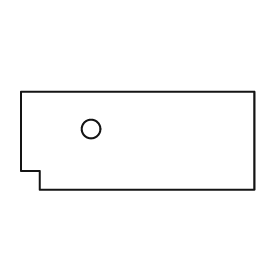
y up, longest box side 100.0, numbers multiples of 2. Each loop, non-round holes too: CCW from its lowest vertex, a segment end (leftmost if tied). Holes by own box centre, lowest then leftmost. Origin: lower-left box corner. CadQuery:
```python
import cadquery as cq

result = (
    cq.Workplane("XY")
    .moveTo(8.0, 0.0)
    .lineTo(100.0, 0.0)
    .lineTo(100.0, 42.0)
    .lineTo(0.0, 42.0)
    .lineTo(0.0, 8.0)
    .lineTo(8.0, 8.0)
    .close()
    .moveTo(30.0, 26.0)
    .circle(4.0)
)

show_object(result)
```